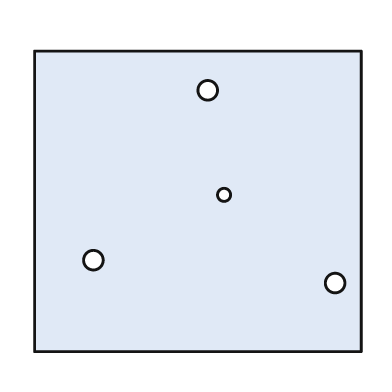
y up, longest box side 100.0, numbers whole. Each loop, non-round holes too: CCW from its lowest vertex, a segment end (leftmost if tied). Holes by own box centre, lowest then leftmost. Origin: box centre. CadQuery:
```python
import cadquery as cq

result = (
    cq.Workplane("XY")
    .moveTo(-50.0, -46.0)
    .lineTo(50.0, -46.0)
    .lineTo(50.0, 46.0)
    .lineTo(-50.0, 46.0)
    .close()
    .moveTo(42.0, -25.0)
    .circle(3.0)
    .moveTo(-32.0, -18.0)
    .circle(3.0)
    .moveTo(8.0, 2.0)
    .circle(2.0)
    .moveTo(3.0, 34.0)
    .circle(3.0)
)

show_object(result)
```